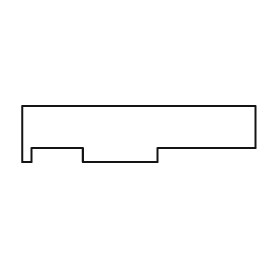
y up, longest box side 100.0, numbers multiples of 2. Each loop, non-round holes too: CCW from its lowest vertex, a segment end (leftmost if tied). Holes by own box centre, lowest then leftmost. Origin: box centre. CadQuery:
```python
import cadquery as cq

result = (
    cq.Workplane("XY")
    .moveTo(-50.0, -12.0)
    .lineTo(-46.0, -12.0)
    .lineTo(-46.0, -6.0)
    .lineTo(-24.0, -6.0)
    .lineTo(-24.0, -12.0)
    .lineTo(8.0, -12.0)
    .lineTo(8.0, -6.0)
    .lineTo(50.0, -6.0)
    .lineTo(50.0, 12.0)
    .lineTo(-50.0, 12.0)
    .close()
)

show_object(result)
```